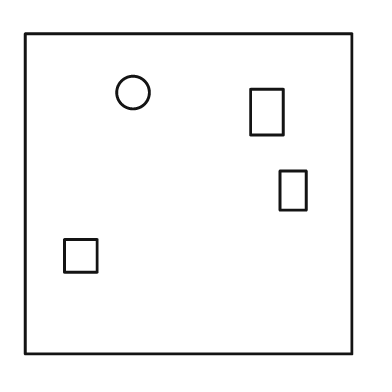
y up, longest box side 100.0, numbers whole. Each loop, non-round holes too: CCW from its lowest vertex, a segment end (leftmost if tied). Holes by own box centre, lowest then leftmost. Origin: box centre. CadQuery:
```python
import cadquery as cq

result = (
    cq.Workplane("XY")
    .moveTo(-50.0, -49.0)
    .lineTo(50.0, -49.0)
    .lineTo(50.0, 49.0)
    .lineTo(-50.0, 49.0)
    .close()
    .moveTo(-38.0, -24.0)
    .lineTo(-28.0, -24.0)
    .lineTo(-28.0, -14.0)
    .lineTo(-38.0, -14.0)
    .close()
    .moveTo(28.0, -5.0)
    .lineTo(36.0, -5.0)
    .lineTo(36.0, 7.0)
    .lineTo(28.0, 7.0)
    .close()
    .moveTo(19.0, 18.0)
    .lineTo(29.0, 18.0)
    .lineTo(29.0, 32.0)
    .lineTo(19.0, 32.0)
    .close()
    .moveTo(-17.0, 31.0)
    .circle(5.0)
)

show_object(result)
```